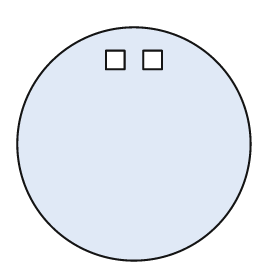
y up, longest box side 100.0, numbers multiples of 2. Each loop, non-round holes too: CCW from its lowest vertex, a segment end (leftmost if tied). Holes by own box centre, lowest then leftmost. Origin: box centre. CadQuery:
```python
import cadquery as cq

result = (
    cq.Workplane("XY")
    .moveTo(0.0, 0.0)
    .circle(50.0)
    .moveTo(-12.0, 32.0)
    .lineTo(-4.0, 32.0)
    .lineTo(-4.0, 40.0)
    .lineTo(-12.0, 40.0)
    .close()
    .moveTo(4.0, 32.0)
    .lineTo(12.0, 32.0)
    .lineTo(12.0, 40.0)
    .lineTo(4.0, 40.0)
    .close()
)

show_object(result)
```